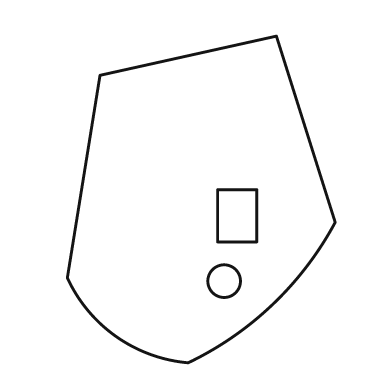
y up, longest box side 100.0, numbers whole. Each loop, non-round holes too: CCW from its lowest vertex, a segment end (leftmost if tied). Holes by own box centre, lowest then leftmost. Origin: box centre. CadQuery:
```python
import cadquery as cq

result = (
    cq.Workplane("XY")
    .moveTo(-4.0, -50.0)
    .threePointArc((22.0, -32.0), (41.0, -7.0))
    .lineTo(23.0, 50.0)
    .lineTo(-31.0, 38.0)
    .lineTo(-41.0, -24.0)
    .threePointArc((-26.0, -42.0), (-4.0, -50.0))
    .close()
    .moveTo(7.0, -25.0)
    .circle(5.0)
    .moveTo(5.0, -13.0)
    .lineTo(17.0, -13.0)
    .lineTo(17.0, 3.0)
    .lineTo(5.0, 3.0)
    .close()
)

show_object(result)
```